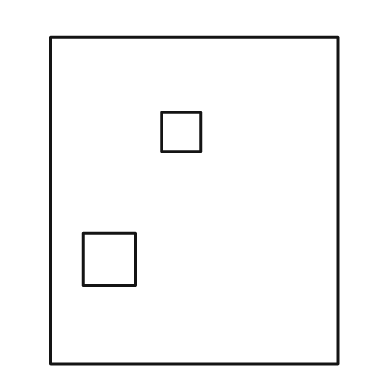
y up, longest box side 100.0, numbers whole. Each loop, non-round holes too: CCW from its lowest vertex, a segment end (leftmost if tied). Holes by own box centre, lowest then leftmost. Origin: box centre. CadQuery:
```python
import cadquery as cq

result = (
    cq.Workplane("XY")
    .moveTo(-44.0, -50.0)
    .lineTo(44.0, -50.0)
    .lineTo(44.0, 50.0)
    .lineTo(-44.0, 50.0)
    .close()
    .moveTo(-34.0, -26.0)
    .lineTo(-18.0, -26.0)
    .lineTo(-18.0, -10.0)
    .lineTo(-34.0, -10.0)
    .close()
    .moveTo(-10.0, 15.0)
    .lineTo(2.0, 15.0)
    .lineTo(2.0, 27.0)
    .lineTo(-10.0, 27.0)
    .close()
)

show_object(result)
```